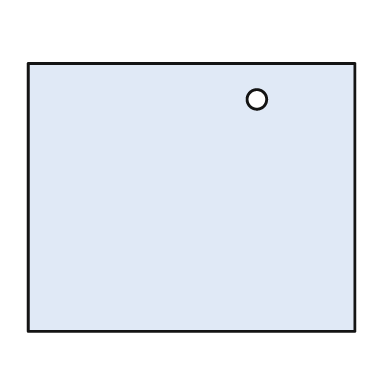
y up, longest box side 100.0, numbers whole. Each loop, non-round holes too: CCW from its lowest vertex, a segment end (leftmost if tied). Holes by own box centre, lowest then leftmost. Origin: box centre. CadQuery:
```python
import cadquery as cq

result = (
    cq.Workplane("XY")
    .moveTo(-50.0, -41.0)
    .lineTo(50.0, -41.0)
    .lineTo(50.0, 41.0)
    .lineTo(-50.0, 41.0)
    .close()
    .moveTo(20.0, 30.0)
    .circle(3.0)
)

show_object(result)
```